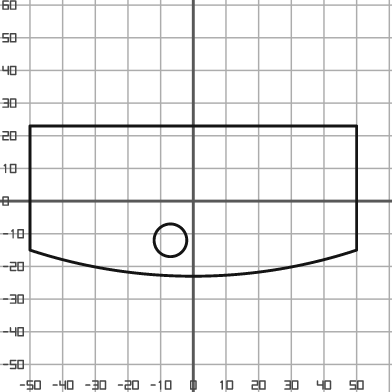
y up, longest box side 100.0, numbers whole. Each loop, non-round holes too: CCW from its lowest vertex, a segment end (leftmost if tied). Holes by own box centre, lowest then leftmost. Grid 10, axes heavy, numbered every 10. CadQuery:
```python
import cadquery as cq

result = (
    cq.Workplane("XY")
    .moveTo(-50.0, -15.0)
    .threePointArc((0.0, -23.0), (50.0, -15.0))
    .lineTo(50.0, 23.0)
    .lineTo(-50.0, 23.0)
    .close()
    .moveTo(-7.0, -12.0)
    .circle(5.0)
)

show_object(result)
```